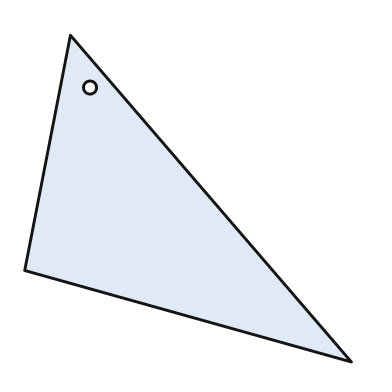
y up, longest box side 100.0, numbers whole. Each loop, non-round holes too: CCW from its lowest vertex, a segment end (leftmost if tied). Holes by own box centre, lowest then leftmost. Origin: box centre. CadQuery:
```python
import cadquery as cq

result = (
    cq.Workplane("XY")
    .moveTo(50.0, -50.0)
    .lineTo(-36.0, 50.0)
    .lineTo(-50.0, -22.0)
    .close()
    .moveTo(-30.0, 34.0)
    .circle(2.0)
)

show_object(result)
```